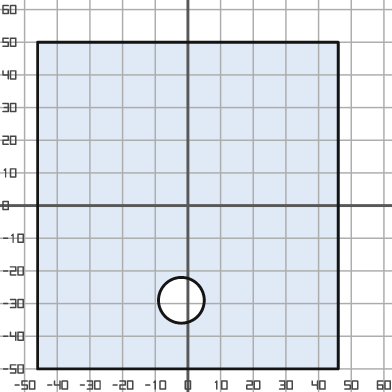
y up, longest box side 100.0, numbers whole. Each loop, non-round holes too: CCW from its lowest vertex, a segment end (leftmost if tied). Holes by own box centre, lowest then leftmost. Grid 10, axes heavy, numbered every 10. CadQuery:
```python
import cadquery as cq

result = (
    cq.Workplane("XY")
    .moveTo(-46.0, -50.0)
    .lineTo(46.0, -50.0)
    .lineTo(46.0, 50.0)
    .lineTo(-46.0, 50.0)
    .close()
    .moveTo(-2.0, -29.0)
    .circle(7.0)
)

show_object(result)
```